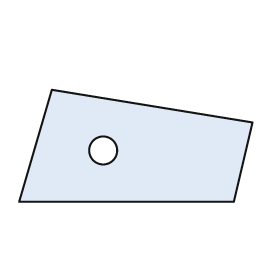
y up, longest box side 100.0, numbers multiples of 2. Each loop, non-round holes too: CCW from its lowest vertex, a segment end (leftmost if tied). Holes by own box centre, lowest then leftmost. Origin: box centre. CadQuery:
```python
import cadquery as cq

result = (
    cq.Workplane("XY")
    .moveTo(-50.0, -24.0)
    .lineTo(42.0, -24.0)
    .lineTo(50.0, 10.0)
    .lineTo(-36.0, 24.0)
    .close()
    .moveTo(-14.0, -2.0)
    .circle(6.0)
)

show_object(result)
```